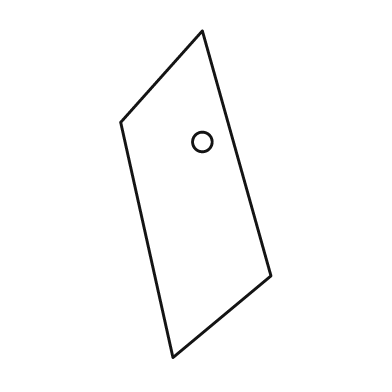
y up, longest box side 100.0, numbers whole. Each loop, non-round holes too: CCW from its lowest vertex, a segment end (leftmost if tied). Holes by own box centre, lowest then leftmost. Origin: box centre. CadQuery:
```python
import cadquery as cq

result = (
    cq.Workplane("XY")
    .moveTo(-7.0, -50.0)
    .lineTo(23.0, -25.0)
    .lineTo(2.0, 50.0)
    .lineTo(-23.0, 22.0)
    .close()
    .moveTo(2.0, 16.0)
    .circle(3.0)
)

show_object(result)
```